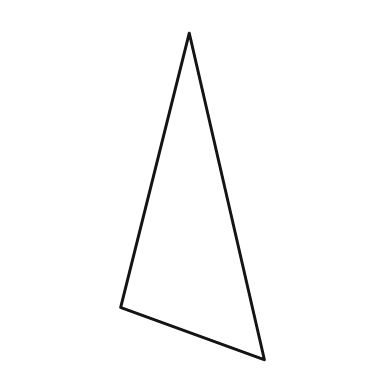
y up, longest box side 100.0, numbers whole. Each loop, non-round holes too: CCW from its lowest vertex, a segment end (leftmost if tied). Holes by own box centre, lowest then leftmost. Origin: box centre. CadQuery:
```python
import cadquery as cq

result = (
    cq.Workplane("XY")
    .moveTo(22.0, -50.0)
    .lineTo(-1.0, 50.0)
    .lineTo(-22.0, -34.0)
    .close()
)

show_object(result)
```